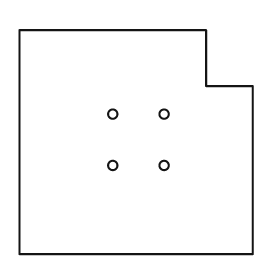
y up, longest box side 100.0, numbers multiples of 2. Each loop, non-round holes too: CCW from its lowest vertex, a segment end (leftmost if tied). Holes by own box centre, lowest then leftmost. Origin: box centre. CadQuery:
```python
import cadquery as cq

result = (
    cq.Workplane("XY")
    .moveTo(-50.0, -48.0)
    .lineTo(50.0, -48.0)
    .lineTo(50.0, 24.0)
    .lineTo(30.0, 24.0)
    .lineTo(30.0, 48.0)
    .lineTo(-50.0, 48.0)
    .close()
    .moveTo(-10.0, -10.0)
    .circle(2.0)
    .moveTo(12.0, -10.0)
    .circle(2.0)
    .moveTo(-10.0, 12.0)
    .circle(2.0)
    .moveTo(12.0, 12.0)
    .circle(2.0)
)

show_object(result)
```